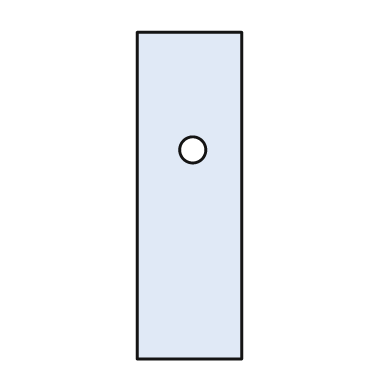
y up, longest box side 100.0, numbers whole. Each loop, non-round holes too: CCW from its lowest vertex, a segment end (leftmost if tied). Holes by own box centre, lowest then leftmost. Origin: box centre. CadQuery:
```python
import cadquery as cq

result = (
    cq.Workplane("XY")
    .moveTo(-16.0, -50.0)
    .lineTo(16.0, -50.0)
    .lineTo(16.0, 50.0)
    .lineTo(-16.0, 50.0)
    .close()
    .moveTo(1.0, 14.0)
    .circle(4.0)
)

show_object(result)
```